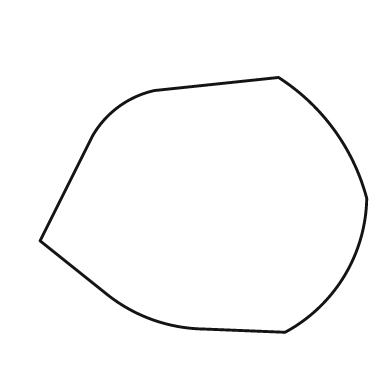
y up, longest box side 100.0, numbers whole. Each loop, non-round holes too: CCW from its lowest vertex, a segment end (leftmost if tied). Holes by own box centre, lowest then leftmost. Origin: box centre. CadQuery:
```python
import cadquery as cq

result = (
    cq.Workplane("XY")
    .moveTo(25.0, -39.0)
    .threePointArc((43.0, -22.0), (50.0, 2.0))
    .threePointArc((40.0, 23.0), (23.0, 39.0))
    .lineTo(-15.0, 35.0)
    .threePointArc((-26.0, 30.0), (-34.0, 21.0))
    .lineTo(-50.0, -11.0)
    .lineTo(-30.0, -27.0)
    .threePointArc((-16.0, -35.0), (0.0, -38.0))
    .close()
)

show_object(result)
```